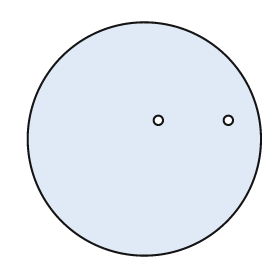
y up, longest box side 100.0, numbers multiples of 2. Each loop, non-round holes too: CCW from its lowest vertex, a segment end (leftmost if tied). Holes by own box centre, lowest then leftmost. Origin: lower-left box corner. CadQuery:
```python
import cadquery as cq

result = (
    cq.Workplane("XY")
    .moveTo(50.0, 50.0)
    .circle(50.0)
    .moveTo(56.0, 58.0)
    .circle(2.0)
    .moveTo(86.0, 58.0)
    .circle(2.0)
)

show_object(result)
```